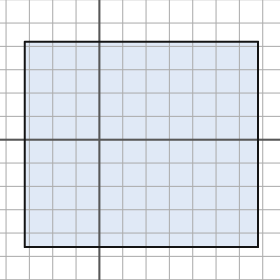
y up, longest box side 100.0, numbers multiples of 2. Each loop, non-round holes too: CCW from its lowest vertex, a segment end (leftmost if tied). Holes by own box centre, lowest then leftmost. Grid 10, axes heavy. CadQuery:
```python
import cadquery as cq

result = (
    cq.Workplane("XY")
    .moveTo(-32.0, -46.0)
    .lineTo(68.0, -46.0)
    .lineTo(68.0, 42.0)
    .lineTo(-32.0, 42.0)
    .close()
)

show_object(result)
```